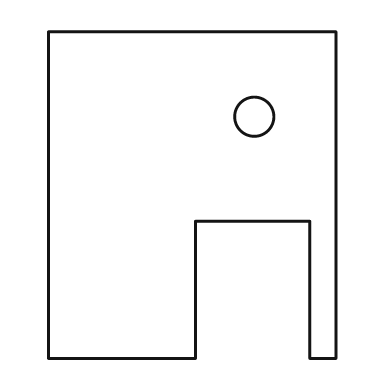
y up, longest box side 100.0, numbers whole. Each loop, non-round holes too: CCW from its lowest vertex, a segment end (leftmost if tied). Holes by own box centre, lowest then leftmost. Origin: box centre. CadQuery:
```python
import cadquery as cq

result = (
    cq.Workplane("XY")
    .moveTo(-44.0, -50.0)
    .lineTo(1.0, -50.0)
    .lineTo(1.0, -8.0)
    .lineTo(36.0, -8.0)
    .lineTo(36.0, -50.0)
    .lineTo(44.0, -50.0)
    .lineTo(44.0, 50.0)
    .lineTo(-44.0, 50.0)
    .close()
    .moveTo(19.0, 24.0)
    .circle(6.0)
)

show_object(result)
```